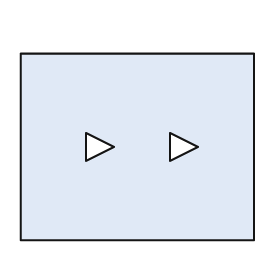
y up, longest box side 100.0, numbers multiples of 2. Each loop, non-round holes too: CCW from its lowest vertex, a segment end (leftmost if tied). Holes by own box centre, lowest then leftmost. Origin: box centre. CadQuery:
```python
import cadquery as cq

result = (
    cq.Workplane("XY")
    .moveTo(-50.0, -40.0)
    .lineTo(50.0, -40.0)
    .lineTo(50.0, 40.0)
    .lineTo(-50.0, 40.0)
    .close()
    .moveTo(-22.0, -6.0)
    .lineTo(-10.0, 0.0)
    .lineTo(-22.0, 6.0)
    .close()
    .moveTo(14.0, -6.0)
    .lineTo(26.0, 0.0)
    .lineTo(14.0, 6.0)
    .close()
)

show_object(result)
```